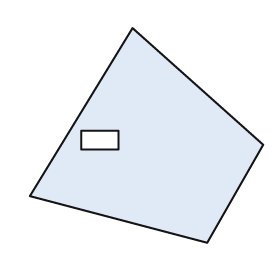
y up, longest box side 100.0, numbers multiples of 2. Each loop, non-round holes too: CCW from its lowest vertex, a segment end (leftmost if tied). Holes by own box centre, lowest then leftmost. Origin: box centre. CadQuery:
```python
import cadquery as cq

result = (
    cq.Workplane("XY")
    .moveTo(26.0, -46.0)
    .lineTo(50.0, -4.0)
    .lineTo(-6.0, 46.0)
    .lineTo(-50.0, -26.0)
    .close()
    .moveTo(-28.0, -6.0)
    .lineTo(-12.0, -6.0)
    .lineTo(-12.0, 2.0)
    .lineTo(-28.0, 2.0)
    .close()
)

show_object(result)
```